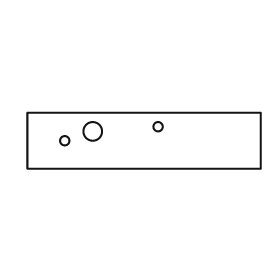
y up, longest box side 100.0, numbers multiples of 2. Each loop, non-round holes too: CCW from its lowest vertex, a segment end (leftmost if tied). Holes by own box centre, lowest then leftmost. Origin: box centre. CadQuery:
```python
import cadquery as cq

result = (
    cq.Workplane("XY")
    .moveTo(-50.0, -12.0)
    .lineTo(50.0, -12.0)
    .lineTo(50.0, 12.0)
    .lineTo(-50.0, 12.0)
    .close()
    .moveTo(-34.0, 0.0)
    .circle(2.0)
    .moveTo(-22.0, 4.0)
    .circle(4.0)
    .moveTo(6.0, 6.0)
    .circle(2.0)
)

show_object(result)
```